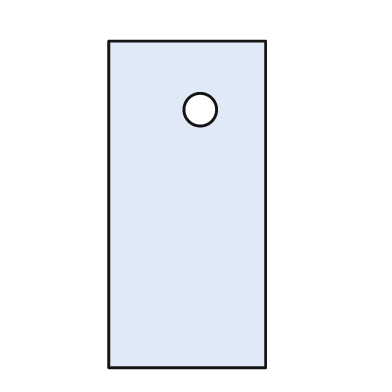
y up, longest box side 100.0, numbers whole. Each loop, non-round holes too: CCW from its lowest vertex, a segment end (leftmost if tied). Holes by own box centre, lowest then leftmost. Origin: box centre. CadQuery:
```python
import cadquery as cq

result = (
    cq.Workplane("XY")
    .moveTo(-24.0, -50.0)
    .lineTo(24.0, -50.0)
    .lineTo(24.0, 50.0)
    .lineTo(-24.0, 50.0)
    .close()
    .moveTo(4.0, 29.0)
    .circle(5.0)
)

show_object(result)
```